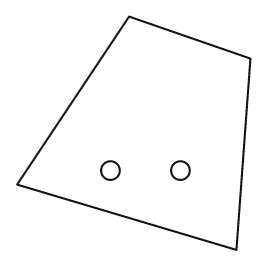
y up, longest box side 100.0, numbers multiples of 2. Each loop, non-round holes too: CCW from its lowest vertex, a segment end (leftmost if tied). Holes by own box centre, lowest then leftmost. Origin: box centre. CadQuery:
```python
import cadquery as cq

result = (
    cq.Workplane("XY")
    .moveTo(44.0, -50.0)
    .lineTo(50.0, 32.0)
    .lineTo(-2.0, 50.0)
    .lineTo(-50.0, -22.0)
    .close()
    .moveTo(-10.0, -16.0)
    .circle(4.0)
    .moveTo(20.0, -16.0)
    .circle(4.0)
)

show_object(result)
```